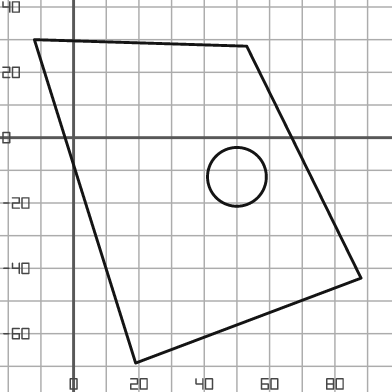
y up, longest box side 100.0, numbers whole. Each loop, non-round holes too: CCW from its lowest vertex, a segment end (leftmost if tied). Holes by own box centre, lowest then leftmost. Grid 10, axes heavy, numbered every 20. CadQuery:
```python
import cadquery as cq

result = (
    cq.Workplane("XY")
    .moveTo(19.0, -69.0)
    .lineTo(88.0, -43.0)
    .lineTo(53.0, 28.0)
    .lineTo(-12.0, 30.0)
    .close()
    .moveTo(50.0, -12.0)
    .circle(9.0)
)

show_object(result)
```